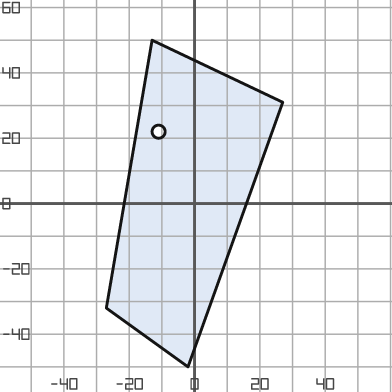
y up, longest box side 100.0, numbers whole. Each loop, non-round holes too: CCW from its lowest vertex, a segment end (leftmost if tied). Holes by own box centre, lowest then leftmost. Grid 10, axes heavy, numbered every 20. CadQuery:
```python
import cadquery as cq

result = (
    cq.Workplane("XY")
    .moveTo(-2.0, -50.0)
    .lineTo(27.0, 31.0)
    .lineTo(-13.0, 50.0)
    .lineTo(-27.0, -32.0)
    .close()
    .moveTo(-11.0, 22.0)
    .circle(2.0)
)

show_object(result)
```